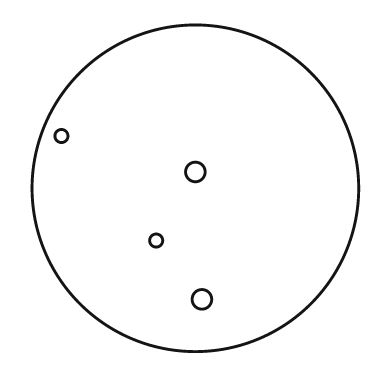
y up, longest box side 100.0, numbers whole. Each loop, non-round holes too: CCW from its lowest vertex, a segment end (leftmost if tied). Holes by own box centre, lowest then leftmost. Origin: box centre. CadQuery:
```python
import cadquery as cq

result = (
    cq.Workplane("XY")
    .moveTo(0.0, 0.0)
    .circle(50.0)
    .moveTo(2.0, -34.0)
    .circle(3.0)
    .moveTo(-12.0, -16.0)
    .circle(2.0)
    .moveTo(0.0, 5.0)
    .circle(3.0)
    .moveTo(-41.0, 16.0)
    .circle(2.0)
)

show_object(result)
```